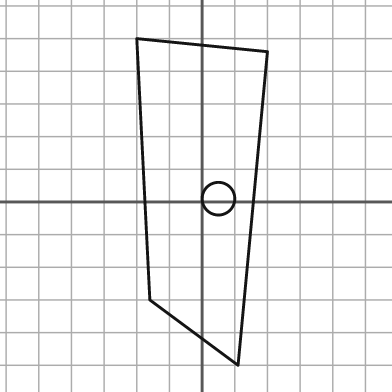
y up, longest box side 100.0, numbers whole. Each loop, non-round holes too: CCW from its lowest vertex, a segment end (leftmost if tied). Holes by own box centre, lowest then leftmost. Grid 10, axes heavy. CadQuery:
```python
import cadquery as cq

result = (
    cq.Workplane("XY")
    .moveTo(11.0, -50.0)
    .lineTo(20.0, 46.0)
    .lineTo(-20.0, 50.0)
    .lineTo(-16.0, -30.0)
    .close()
    .moveTo(5.0, 1.0)
    .circle(5.0)
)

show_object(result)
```